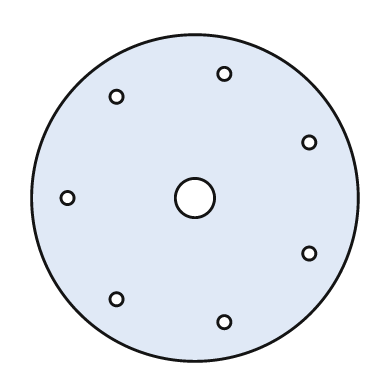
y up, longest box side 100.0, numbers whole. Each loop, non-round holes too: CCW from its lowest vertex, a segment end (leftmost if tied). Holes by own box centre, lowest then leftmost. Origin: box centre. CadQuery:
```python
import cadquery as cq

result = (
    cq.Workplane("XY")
    .moveTo(0.0, 0.0)
    .circle(50.0)
    .moveTo(9.0, -38.0)
    .circle(2.0)
    .moveTo(-24.0, -31.0)
    .circle(2.0)
    .moveTo(35.0, -17.0)
    .circle(2.0)
    .moveTo(-39.0, 0.0)
    .circle(2.0)
    .moveTo(0.0, 0.0)
    .circle(6.0)
    .moveTo(35.0, 17.0)
    .circle(2.0)
    .moveTo(-24.0, 31.0)
    .circle(2.0)
    .moveTo(9.0, 38.0)
    .circle(2.0)
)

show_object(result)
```